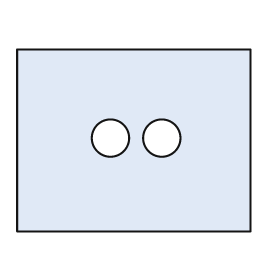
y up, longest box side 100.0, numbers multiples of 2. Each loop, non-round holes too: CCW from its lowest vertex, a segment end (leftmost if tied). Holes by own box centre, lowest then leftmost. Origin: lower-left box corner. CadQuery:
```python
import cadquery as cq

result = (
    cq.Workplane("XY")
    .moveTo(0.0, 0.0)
    .lineTo(100.0, 0.0)
    .lineTo(100.0, 78.0)
    .lineTo(0.0, 78.0)
    .close()
    .moveTo(40.0, 40.0)
    .circle(8.0)
    .moveTo(62.0, 40.0)
    .circle(8.0)
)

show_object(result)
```